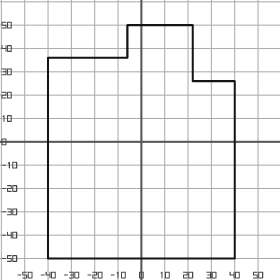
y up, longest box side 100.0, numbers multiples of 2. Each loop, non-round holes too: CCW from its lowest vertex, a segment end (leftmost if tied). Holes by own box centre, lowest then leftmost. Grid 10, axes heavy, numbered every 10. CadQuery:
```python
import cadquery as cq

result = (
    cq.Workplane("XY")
    .moveTo(-40.0, -50.0)
    .lineTo(40.0, -50.0)
    .lineTo(40.0, 26.0)
    .lineTo(22.0, 26.0)
    .lineTo(22.0, 50.0)
    .lineTo(-6.0, 50.0)
    .lineTo(-6.0, 36.0)
    .lineTo(-40.0, 36.0)
    .close()
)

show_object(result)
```